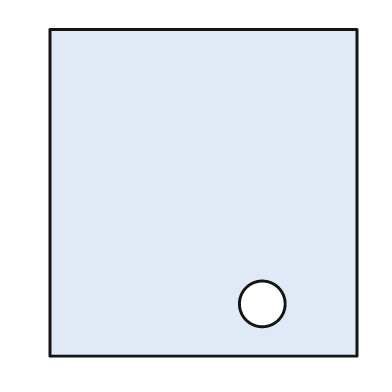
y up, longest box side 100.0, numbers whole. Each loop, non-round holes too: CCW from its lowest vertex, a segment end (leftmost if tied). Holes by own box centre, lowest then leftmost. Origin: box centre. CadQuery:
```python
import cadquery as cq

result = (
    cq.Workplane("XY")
    .moveTo(-47.0, -50.0)
    .lineTo(47.0, -50.0)
    .lineTo(47.0, 50.0)
    .lineTo(-47.0, 50.0)
    .close()
    .moveTo(18.0, -34.0)
    .circle(7.0)
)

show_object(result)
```